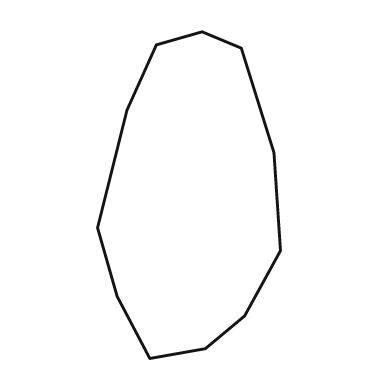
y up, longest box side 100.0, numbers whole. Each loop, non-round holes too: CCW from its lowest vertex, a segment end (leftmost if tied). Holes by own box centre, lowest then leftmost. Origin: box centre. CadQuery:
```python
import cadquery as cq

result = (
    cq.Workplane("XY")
    .moveTo(-12.0, -50.0)
    .lineTo(5.0, -47.0)
    .lineTo(17.0, -37.0)
    .lineTo(28.0, -17.0)
    .lineTo(26.0, 13.0)
    .lineTo(16.0, 45.0)
    .lineTo(4.0, 50.0)
    .lineTo(-10.0, 46.0)
    .lineTo(-19.0, 26.0)
    .lineTo(-28.0, -10.0)
    .lineTo(-22.0, -31.0)
    .close()
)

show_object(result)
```